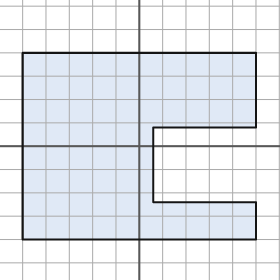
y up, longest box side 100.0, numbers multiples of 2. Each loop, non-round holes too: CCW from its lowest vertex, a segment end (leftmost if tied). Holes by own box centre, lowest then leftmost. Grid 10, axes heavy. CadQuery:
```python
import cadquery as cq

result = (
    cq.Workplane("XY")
    .moveTo(-50.0, -40.0)
    .lineTo(50.0, -40.0)
    .lineTo(50.0, -24.0)
    .lineTo(6.0, -24.0)
    .lineTo(6.0, 8.0)
    .lineTo(50.0, 8.0)
    .lineTo(50.0, 40.0)
    .lineTo(-50.0, 40.0)
    .close()
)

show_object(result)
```